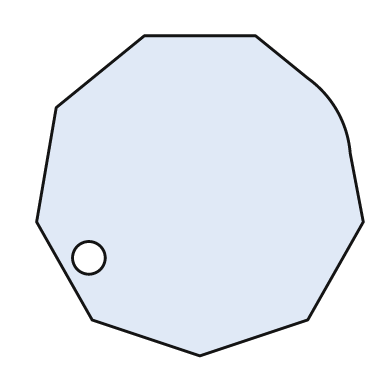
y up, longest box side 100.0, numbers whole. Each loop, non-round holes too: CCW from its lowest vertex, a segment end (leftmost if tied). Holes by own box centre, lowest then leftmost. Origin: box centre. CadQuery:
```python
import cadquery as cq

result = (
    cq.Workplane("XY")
    .moveTo(0.0, -49.0)
    .lineTo(33.0, -38.0)
    .lineTo(50.0, -8.0)
    .lineTo(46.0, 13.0)
    .threePointArc((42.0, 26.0), (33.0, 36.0))
    .lineTo(17.0, 49.0)
    .lineTo(-17.0, 49.0)
    .lineTo(-44.0, 27.0)
    .lineTo(-50.0, -8.0)
    .lineTo(-33.0, -38.0)
    .close()
    .moveTo(-34.0, -19.0)
    .circle(5.0)
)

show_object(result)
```